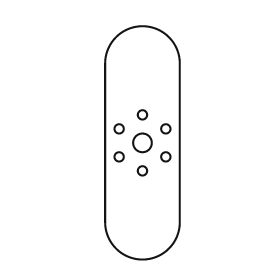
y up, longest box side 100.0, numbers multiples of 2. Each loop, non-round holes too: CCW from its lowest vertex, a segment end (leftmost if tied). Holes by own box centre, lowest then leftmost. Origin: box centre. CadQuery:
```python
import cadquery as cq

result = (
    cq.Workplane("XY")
    .moveTo(-16.0, -34.0)
    .threePointArc((0.0, -50.0), (16.0, -34.0))
    .lineTo(16.0, 34.0)
    .threePointArc((0.0, 50.0), (-16.0, 34.0))
    .close()
    .moveTo(0.0, -12.0)
    .circle(2.0)
    .moveTo(-10.0, -6.0)
    .circle(2.0)
    .moveTo(10.0, -6.0)
    .circle(2.0)
    .moveTo(0.0, 0.0)
    .circle(4.0)
    .moveTo(-10.0, 6.0)
    .circle(2.0)
    .moveTo(10.0, 6.0)
    .circle(2.0)
    .moveTo(0.0, 12.0)
    .circle(2.0)
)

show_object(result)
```